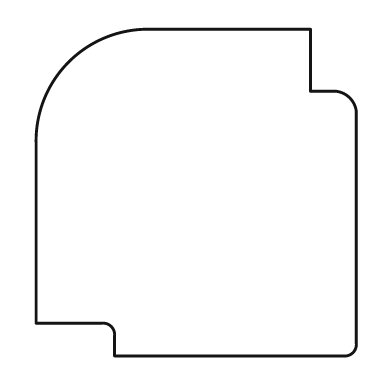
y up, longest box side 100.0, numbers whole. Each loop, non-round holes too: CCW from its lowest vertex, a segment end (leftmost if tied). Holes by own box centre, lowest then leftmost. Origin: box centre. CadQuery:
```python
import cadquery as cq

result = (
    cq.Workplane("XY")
    .moveTo(-25.0, -50.0)
    .lineTo(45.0, -50.0)
    .threePointArc((48.0, -49.0), (49.0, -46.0))
    .lineTo(49.0, 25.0)
    .threePointArc((47.0, 29.0), (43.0, 31.0))
    .lineTo(35.0, 31.0)
    .lineTo(35.0, 50.0)
    .lineTo(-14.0, 50.0)
    .threePointArc((-39.0, 40.0), (-49.0, 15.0))
    .lineTo(-49.0, -40.0)
    .lineTo(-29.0, -40.0)
    .threePointArc((-26.0, -41.0), (-25.0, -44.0))
    .close()
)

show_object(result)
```